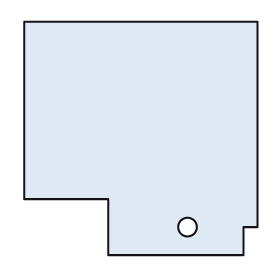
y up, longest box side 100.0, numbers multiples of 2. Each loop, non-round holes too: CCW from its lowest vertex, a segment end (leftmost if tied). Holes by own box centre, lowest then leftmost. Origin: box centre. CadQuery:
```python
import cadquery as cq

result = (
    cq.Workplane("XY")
    .moveTo(-14.0, -50.0)
    .lineTo(44.0, -50.0)
    .lineTo(44.0, -38.0)
    .lineTo(50.0, -38.0)
    .lineTo(50.0, 50.0)
    .lineTo(-50.0, 50.0)
    .lineTo(-50.0, -26.0)
    .lineTo(-14.0, -26.0)
    .close()
    .moveTo(20.0, -38.0)
    .circle(4.0)
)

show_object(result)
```